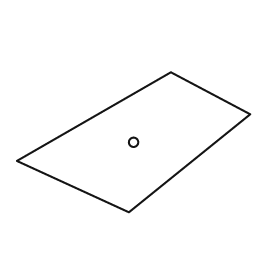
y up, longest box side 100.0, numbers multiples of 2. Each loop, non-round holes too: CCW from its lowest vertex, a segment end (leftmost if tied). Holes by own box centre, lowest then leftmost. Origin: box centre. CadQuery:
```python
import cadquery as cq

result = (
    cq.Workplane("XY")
    .moveTo(-2.0, -30.0)
    .lineTo(50.0, 12.0)
    .lineTo(16.0, 30.0)
    .lineTo(-50.0, -8.0)
    .close()
    .moveTo(0.0, 0.0)
    .circle(2.0)
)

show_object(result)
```